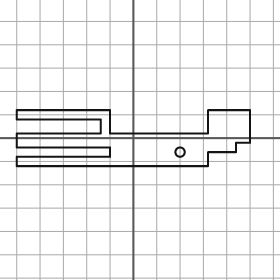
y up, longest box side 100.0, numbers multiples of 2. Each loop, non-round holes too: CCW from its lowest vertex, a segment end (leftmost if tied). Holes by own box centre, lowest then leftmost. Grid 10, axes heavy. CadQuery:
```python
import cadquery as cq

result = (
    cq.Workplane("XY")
    .moveTo(-50.0, -12.0)
    .lineTo(32.0, -12.0)
    .lineTo(32.0, -6.0)
    .lineTo(44.0, -6.0)
    .lineTo(44.0, -2.0)
    .lineTo(50.0, -2.0)
    .lineTo(50.0, 12.0)
    .lineTo(32.0, 12.0)
    .lineTo(32.0, 2.0)
    .lineTo(-10.0, 2.0)
    .lineTo(-10.0, 12.0)
    .lineTo(-50.0, 12.0)
    .lineTo(-50.0, 8.0)
    .lineTo(-14.0, 8.0)
    .lineTo(-14.0, 2.0)
    .lineTo(-50.0, 2.0)
    .lineTo(-50.0, -4.0)
    .lineTo(-10.0, -4.0)
    .lineTo(-10.0, -8.0)
    .lineTo(-50.0, -8.0)
    .close()
    .moveTo(20.0, -6.0)
    .circle(2.0)
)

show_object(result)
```